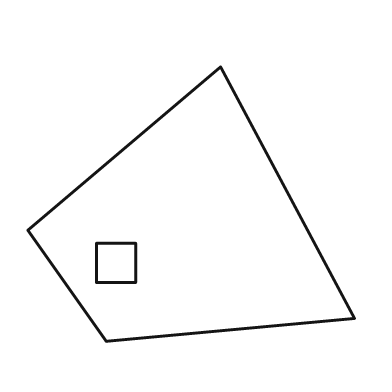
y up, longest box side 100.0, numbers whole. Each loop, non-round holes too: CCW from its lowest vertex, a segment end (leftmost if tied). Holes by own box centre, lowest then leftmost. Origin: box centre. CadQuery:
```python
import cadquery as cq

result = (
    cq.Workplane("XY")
    .moveTo(-26.0, -42.0)
    .lineTo(50.0, -35.0)
    .lineTo(9.0, 42.0)
    .lineTo(-50.0, -8.0)
    .close()
    .moveTo(-29.0, -24.0)
    .lineTo(-17.0, -24.0)
    .lineTo(-17.0, -12.0)
    .lineTo(-29.0, -12.0)
    .close()
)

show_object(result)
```